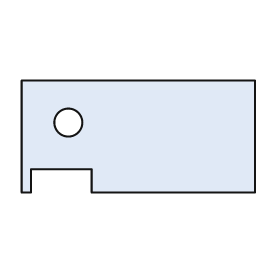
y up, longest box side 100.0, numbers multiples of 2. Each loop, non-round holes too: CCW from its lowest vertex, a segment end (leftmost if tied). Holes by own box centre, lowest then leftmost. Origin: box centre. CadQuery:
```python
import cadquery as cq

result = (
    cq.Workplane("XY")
    .moveTo(-50.0, -24.0)
    .lineTo(-46.0, -24.0)
    .lineTo(-46.0, -14.0)
    .lineTo(-20.0, -14.0)
    .lineTo(-20.0, -24.0)
    .lineTo(50.0, -24.0)
    .lineTo(50.0, 24.0)
    .lineTo(-50.0, 24.0)
    .close()
    .moveTo(-30.0, 6.0)
    .circle(6.0)
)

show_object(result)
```